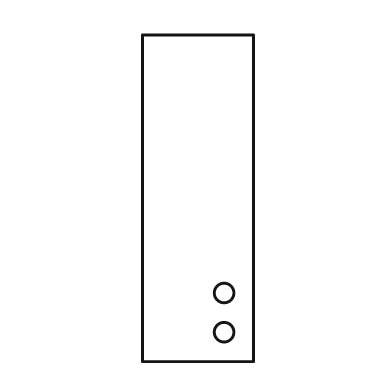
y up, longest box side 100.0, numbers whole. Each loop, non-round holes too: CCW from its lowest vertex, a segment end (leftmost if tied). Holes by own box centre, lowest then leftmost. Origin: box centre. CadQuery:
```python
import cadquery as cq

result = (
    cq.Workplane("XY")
    .moveTo(-17.0, -50.0)
    .lineTo(17.0, -50.0)
    .lineTo(17.0, 50.0)
    .lineTo(-17.0, 50.0)
    .close()
    .moveTo(8.0, -41.0)
    .circle(3.0)
    .moveTo(8.0, -29.0)
    .circle(3.0)
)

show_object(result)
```